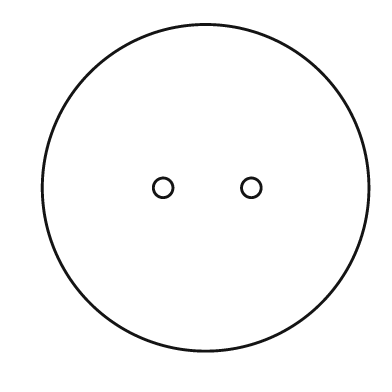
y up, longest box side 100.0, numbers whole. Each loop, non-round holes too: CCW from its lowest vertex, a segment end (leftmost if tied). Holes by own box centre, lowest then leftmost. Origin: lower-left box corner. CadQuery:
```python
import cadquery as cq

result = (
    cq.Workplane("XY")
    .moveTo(50.0, 50.0)
    .circle(50.0)
    .moveTo(37.0, 50.0)
    .circle(3.0)
    .moveTo(64.0, 50.0)
    .circle(3.0)
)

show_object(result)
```